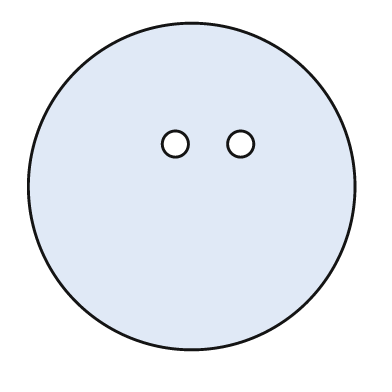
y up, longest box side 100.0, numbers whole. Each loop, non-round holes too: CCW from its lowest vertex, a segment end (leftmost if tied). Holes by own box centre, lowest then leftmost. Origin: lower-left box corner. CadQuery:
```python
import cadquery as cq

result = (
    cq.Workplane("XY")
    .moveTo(50.0, 50.0)
    .circle(50.0)
    .moveTo(45.0, 63.0)
    .circle(4.0)
    .moveTo(65.0, 63.0)
    .circle(4.0)
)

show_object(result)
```